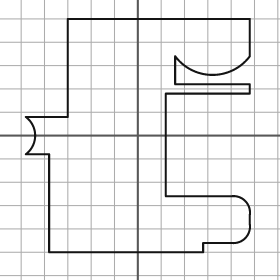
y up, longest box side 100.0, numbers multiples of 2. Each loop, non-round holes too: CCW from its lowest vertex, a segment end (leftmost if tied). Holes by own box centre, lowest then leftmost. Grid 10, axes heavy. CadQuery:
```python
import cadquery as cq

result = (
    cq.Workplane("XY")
    .moveTo(-38.0, -50.0)
    .lineTo(28.0, -50.0)
    .lineTo(28.0, -46.0)
    .lineTo(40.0, -46.0)
    .threePointArc((46.0, -44.0), (48.0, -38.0))
    .lineTo(48.0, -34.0)
    .threePointArc((46.0, -28.0), (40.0, -26.0))
    .lineTo(12.0, -26.0)
    .lineTo(12.0, 18.0)
    .lineTo(48.0, 18.0)
    .lineTo(48.0, 22.0)
    .lineTo(16.0, 22.0)
    .lineTo(16.0, 34.0)
    .threePointArc((32.0, 26.0), (48.0, 34.0))
    .lineTo(48.0, 50.0)
    .lineTo(-30.0, 50.0)
    .lineTo(-30.0, 8.0)
    .lineTo(-48.0, 8.0)
    .threePointArc((-44.0, 0.0), (-48.0, -8.0))
    .lineTo(-38.0, -8.0)
    .close()
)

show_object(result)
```